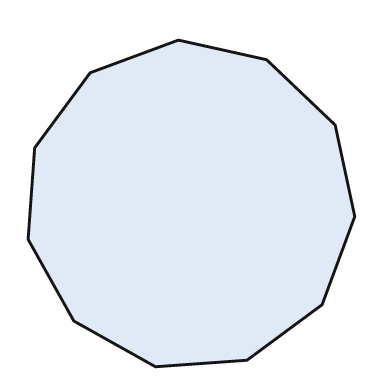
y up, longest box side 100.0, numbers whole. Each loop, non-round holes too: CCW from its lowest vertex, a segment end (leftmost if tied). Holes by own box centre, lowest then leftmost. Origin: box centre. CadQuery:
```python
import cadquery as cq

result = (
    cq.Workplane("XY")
    .moveTo(-11.0, -50.0)
    .lineTo(17.0, -48.0)
    .lineTo(40.0, -31.0)
    .lineTo(50.0, -4.0)
    .lineTo(44.0, 24.0)
    .lineTo(23.0, 44.0)
    .lineTo(-4.0, 50.0)
    .lineTo(-31.0, 40.0)
    .lineTo(-48.0, 17.0)
    .lineTo(-50.0, -11.0)
    .lineTo(-36.0, -36.0)
    .close()
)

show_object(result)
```